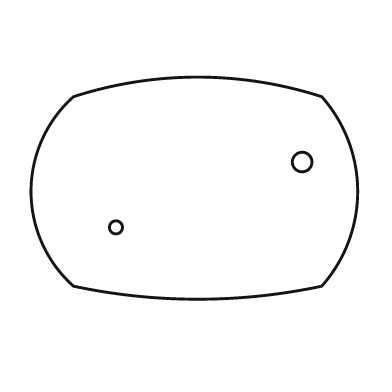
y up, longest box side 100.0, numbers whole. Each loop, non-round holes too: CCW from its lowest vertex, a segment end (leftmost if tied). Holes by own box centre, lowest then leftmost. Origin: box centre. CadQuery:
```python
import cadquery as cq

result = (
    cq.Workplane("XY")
    .moveTo(-37.0, -30.0)
    .threePointArc((1.0, -34.0), (39.0, -30.0))
    .threePointArc((50.0, -1.0), (39.0, 28.0))
    .threePointArc((1.0, 34.0), (-37.0, 28.0))
    .threePointArc((-50.0, -1.0), (-37.0, -30.0))
    .close()
    .moveTo(-24.0, -12.0)
    .circle(2.0)
    .moveTo(33.0, 8.0)
    .circle(3.0)
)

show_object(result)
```